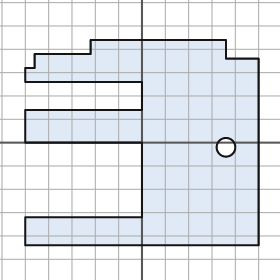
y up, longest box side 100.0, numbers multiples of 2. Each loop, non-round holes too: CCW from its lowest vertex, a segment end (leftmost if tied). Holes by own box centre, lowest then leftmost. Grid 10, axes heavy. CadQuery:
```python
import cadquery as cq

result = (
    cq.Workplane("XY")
    .moveTo(-50.0, -44.0)
    .lineTo(50.0, -44.0)
    .lineTo(50.0, 36.0)
    .lineTo(36.0, 36.0)
    .lineTo(36.0, 44.0)
    .lineTo(-22.0, 44.0)
    .lineTo(-22.0, 38.0)
    .lineTo(-46.0, 38.0)
    .lineTo(-46.0, 32.0)
    .lineTo(-50.0, 32.0)
    .lineTo(-50.0, 26.0)
    .lineTo(0.0, 26.0)
    .lineTo(0.0, 14.0)
    .lineTo(-50.0, 14.0)
    .lineTo(-50.0, 0.0)
    .lineTo(0.0, 0.0)
    .lineTo(0.0, -32.0)
    .lineTo(-50.0, -32.0)
    .close()
    .moveTo(36.0, -2.0)
    .circle(4.0)
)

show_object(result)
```